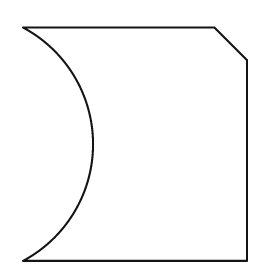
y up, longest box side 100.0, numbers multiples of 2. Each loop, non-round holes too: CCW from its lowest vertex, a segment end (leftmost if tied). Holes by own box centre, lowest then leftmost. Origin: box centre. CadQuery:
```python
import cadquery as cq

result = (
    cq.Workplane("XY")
    .moveTo(-48.0, -50.0)
    .lineTo(48.0, -50.0)
    .lineTo(48.0, 36.0)
    .lineTo(34.0, 50.0)
    .lineTo(-48.0, 50.0)
    .threePointArc((-18.0, 0.0), (-48.0, -50.0))
    .close()
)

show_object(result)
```